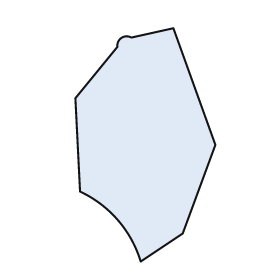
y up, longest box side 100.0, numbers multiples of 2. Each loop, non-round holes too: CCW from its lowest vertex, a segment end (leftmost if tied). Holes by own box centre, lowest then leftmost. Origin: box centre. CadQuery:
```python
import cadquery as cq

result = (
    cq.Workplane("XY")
    .moveTo(-2.0, -50.0)
    .lineTo(16.0, -38.0)
    .lineTo(30.0, 0.0)
    .lineTo(12.0, 50.0)
    .lineTo(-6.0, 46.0)
    .threePointArc((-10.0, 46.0), (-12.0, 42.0))
    .lineTo(-30.0, 20.0)
    .lineTo(-28.0, -20.0)
    .threePointArc((-12.0, -32.0), (-2.0, -50.0))
    .close()
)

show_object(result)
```